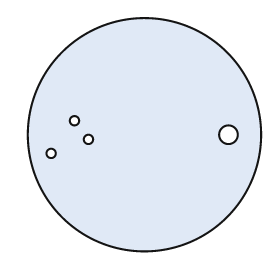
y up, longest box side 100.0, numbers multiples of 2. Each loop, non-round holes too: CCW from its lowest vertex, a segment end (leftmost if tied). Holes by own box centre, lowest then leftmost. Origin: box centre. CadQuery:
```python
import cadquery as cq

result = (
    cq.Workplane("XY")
    .moveTo(0.0, 0.0)
    .circle(50.0)
    .moveTo(-40.0, -8.0)
    .circle(2.0)
    .moveTo(-24.0, -2.0)
    .circle(2.0)
    .moveTo(36.0, 0.0)
    .circle(4.0)
    .moveTo(-30.0, 6.0)
    .circle(2.0)
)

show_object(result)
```